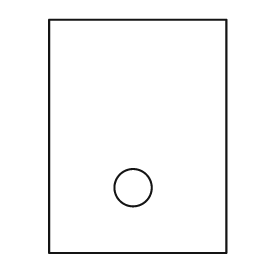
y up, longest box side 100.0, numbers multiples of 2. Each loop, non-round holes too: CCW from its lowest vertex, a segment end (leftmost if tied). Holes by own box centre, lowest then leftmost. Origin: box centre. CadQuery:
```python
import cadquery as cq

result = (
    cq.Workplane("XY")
    .moveTo(-38.0, -50.0)
    .lineTo(38.0, -50.0)
    .lineTo(38.0, 50.0)
    .lineTo(-38.0, 50.0)
    .close()
    .moveTo(-2.0, -22.0)
    .circle(8.0)
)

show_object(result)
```